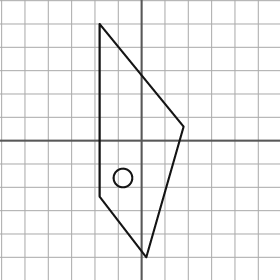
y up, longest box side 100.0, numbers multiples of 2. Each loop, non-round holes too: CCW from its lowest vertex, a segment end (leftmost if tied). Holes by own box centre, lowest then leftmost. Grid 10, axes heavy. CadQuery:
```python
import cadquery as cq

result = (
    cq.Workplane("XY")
    .moveTo(2.0, -50.0)
    .lineTo(18.0, 6.0)
    .lineTo(-18.0, 50.0)
    .lineTo(-18.0, -24.0)
    .close()
    .moveTo(-8.0, -16.0)
    .circle(4.0)
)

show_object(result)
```